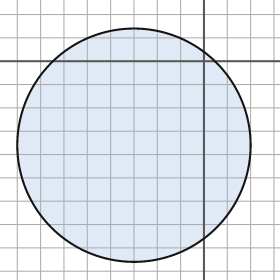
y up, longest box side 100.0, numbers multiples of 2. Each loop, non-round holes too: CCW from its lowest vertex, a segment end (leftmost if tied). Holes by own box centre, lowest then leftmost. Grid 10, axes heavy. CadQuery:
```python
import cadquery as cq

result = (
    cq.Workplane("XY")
    .moveTo(-30.0, -36.0)
    .circle(50.0)
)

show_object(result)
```